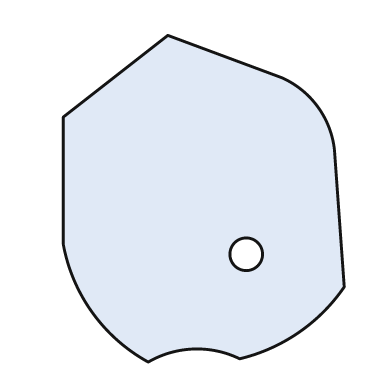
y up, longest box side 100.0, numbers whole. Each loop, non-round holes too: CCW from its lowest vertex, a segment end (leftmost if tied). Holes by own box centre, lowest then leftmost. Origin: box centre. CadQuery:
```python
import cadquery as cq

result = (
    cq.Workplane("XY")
    .moveTo(-17.0, -50.0)
    .threePointArc((-3.0, -46.0), (11.0, -49.0))
    .threePointArc((29.0, -41.0), (43.0, -27.0))
    .lineTo(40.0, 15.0)
    .threePointArc((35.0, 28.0), (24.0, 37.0))
    .lineTo(-11.0, 50.0)
    .lineTo(-43.0, 25.0)
    .lineTo(-43.0, -14.0)
    .threePointArc((-34.0, -35.0), (-17.0, -50.0))
    .close()
    .moveTo(13.0, -17.0)
    .circle(5.0)
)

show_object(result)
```